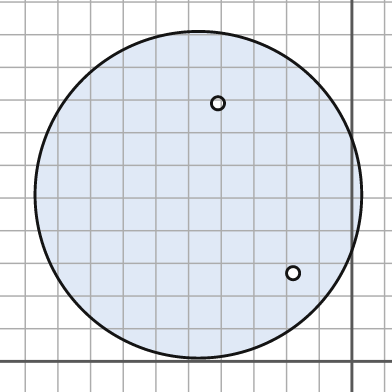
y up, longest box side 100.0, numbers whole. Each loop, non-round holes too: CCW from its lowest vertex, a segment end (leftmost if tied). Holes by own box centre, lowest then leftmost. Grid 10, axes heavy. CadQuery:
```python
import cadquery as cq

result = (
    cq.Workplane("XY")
    .moveTo(-47.0, 51.0)
    .circle(50.0)
    .moveTo(-18.0, 27.0)
    .circle(2.0)
    .moveTo(-41.0, 79.0)
    .circle(2.0)
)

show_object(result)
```